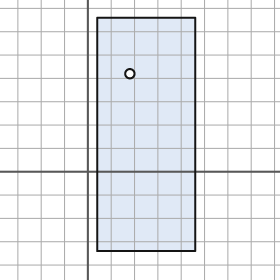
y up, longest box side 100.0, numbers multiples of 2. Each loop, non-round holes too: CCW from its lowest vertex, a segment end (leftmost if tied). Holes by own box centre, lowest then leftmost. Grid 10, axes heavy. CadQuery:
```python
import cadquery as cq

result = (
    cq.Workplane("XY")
    .moveTo(4.0, -34.0)
    .lineTo(46.0, -34.0)
    .lineTo(46.0, 66.0)
    .lineTo(4.0, 66.0)
    .close()
    .moveTo(18.0, 42.0)
    .circle(2.0)
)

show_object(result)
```